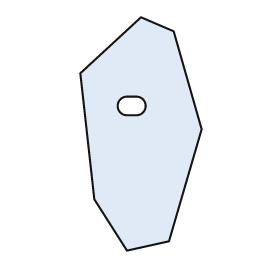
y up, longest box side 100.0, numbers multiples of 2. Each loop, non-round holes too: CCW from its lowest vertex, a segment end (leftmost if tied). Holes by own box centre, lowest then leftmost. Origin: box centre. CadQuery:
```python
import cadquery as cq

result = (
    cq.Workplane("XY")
    .moveTo(-6.0, -50.0)
    .lineTo(12.0, -46.0)
    .lineTo(26.0, 2.0)
    .lineTo(14.0, 44.0)
    .lineTo(0.0, 50.0)
    .lineTo(-26.0, 26.0)
    .lineTo(-20.0, -28.0)
    .close()
    .moveTo(-6.0, 8.0)
    .lineTo(-2.0, 8.0)
    .threePointArc((2.0, 12.0), (-2.0, 16.0))
    .lineTo(-6.0, 16.0)
    .threePointArc((-10.0, 12.0), (-6.0, 8.0))
    .close()
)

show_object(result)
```